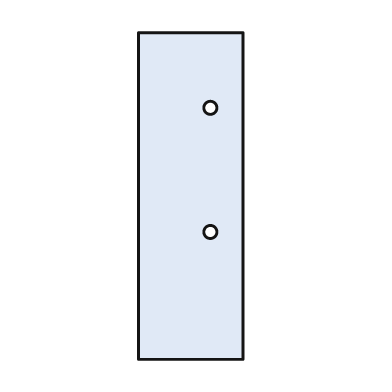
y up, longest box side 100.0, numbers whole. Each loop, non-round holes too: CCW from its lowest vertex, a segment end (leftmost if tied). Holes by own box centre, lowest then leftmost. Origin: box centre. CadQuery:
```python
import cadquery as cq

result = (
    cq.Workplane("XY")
    .moveTo(-16.0, -50.0)
    .lineTo(16.0, -50.0)
    .lineTo(16.0, 50.0)
    .lineTo(-16.0, 50.0)
    .close()
    .moveTo(6.0, -11.0)
    .circle(2.0)
    .moveTo(6.0, 27.0)
    .circle(2.0)
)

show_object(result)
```